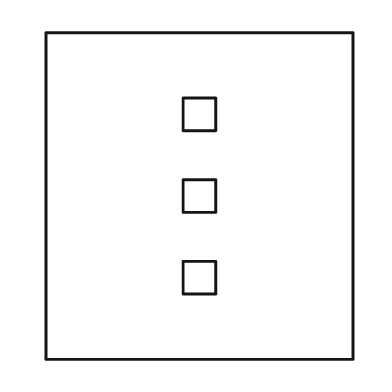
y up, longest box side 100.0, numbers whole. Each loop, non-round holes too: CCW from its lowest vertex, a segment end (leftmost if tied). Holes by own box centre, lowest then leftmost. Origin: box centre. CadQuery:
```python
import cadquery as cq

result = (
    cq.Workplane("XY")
    .moveTo(-47.0, -50.0)
    .lineTo(47.0, -50.0)
    .lineTo(47.0, 50.0)
    .lineTo(-47.0, 50.0)
    .close()
    .moveTo(-5.0, -30.0)
    .lineTo(5.0, -30.0)
    .lineTo(5.0, -20.0)
    .lineTo(-5.0, -20.0)
    .close()
    .moveTo(-5.0, -5.0)
    .lineTo(5.0, -5.0)
    .lineTo(5.0, 5.0)
    .lineTo(-5.0, 5.0)
    .close()
    .moveTo(-5.0, 20.0)
    .lineTo(5.0, 20.0)
    .lineTo(5.0, 30.0)
    .lineTo(-5.0, 30.0)
    .close()
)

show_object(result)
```